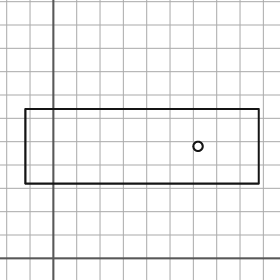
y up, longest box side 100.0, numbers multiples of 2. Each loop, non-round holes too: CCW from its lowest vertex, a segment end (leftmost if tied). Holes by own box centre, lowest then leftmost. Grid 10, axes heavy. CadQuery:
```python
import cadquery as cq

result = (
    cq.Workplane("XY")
    .moveTo(-12.0, 32.0)
    .lineTo(88.0, 32.0)
    .lineTo(88.0, 64.0)
    .lineTo(-12.0, 64.0)
    .close()
    .moveTo(62.0, 48.0)
    .circle(2.0)
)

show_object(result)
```